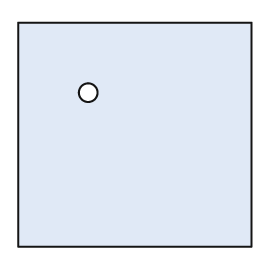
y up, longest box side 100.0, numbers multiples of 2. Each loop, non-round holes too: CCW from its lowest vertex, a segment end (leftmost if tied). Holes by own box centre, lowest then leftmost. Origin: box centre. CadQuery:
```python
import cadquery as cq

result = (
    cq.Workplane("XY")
    .moveTo(-50.0, -48.0)
    .lineTo(50.0, -48.0)
    .lineTo(50.0, 48.0)
    .lineTo(-50.0, 48.0)
    .close()
    .moveTo(-20.0, 18.0)
    .circle(4.0)
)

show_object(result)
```